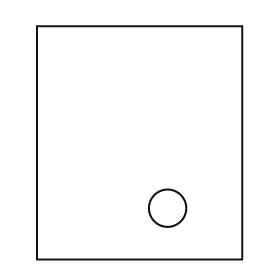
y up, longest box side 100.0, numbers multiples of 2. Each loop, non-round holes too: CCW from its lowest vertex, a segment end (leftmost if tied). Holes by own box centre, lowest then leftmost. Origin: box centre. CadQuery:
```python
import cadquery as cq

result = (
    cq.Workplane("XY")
    .moveTo(-44.0, -50.0)
    .lineTo(44.0, -50.0)
    .lineTo(44.0, 50.0)
    .lineTo(-44.0, 50.0)
    .close()
    .moveTo(12.0, -28.0)
    .circle(8.0)
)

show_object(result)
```